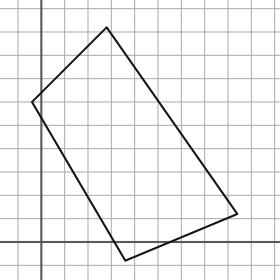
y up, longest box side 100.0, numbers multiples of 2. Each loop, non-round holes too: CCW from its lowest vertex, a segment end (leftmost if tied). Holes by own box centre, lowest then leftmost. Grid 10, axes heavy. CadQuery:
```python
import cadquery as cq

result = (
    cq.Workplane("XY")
    .moveTo(36.0, -8.0)
    .lineTo(84.0, 12.0)
    .lineTo(28.0, 92.0)
    .lineTo(-4.0, 60.0)
    .close()
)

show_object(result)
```